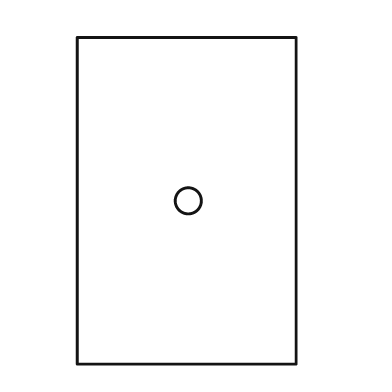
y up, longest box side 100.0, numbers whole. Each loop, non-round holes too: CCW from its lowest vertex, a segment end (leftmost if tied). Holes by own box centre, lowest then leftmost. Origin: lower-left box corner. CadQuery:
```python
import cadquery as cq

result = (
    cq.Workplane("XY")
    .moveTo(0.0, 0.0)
    .lineTo(67.0, 0.0)
    .lineTo(67.0, 100.0)
    .lineTo(0.0, 100.0)
    .close()
    .moveTo(34.0, 50.0)
    .circle(4.0)
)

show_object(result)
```